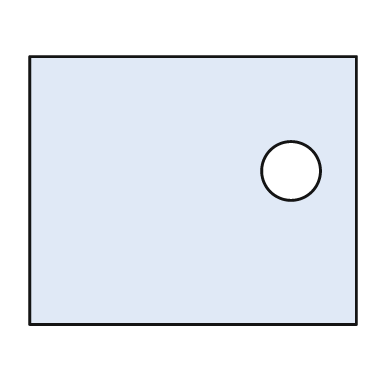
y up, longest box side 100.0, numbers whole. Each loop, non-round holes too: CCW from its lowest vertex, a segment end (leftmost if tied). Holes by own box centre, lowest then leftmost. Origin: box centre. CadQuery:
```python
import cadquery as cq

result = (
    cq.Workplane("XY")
    .moveTo(-50.0, -41.0)
    .lineTo(50.0, -41.0)
    .lineTo(50.0, 41.0)
    .lineTo(-50.0, 41.0)
    .close()
    .moveTo(30.0, 6.0)
    .circle(9.0)
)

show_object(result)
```